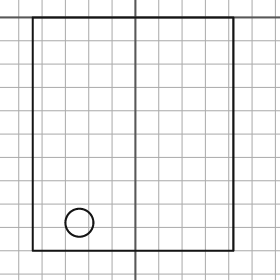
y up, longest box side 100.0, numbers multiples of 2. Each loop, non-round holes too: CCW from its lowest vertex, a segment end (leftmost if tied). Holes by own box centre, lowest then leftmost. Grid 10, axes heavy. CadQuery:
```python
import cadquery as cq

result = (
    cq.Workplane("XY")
    .moveTo(-44.0, -100.0)
    .lineTo(42.0, -100.0)
    .lineTo(42.0, 0.0)
    .lineTo(-44.0, 0.0)
    .close()
    .moveTo(-24.0, -88.0)
    .circle(6.0)
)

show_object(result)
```